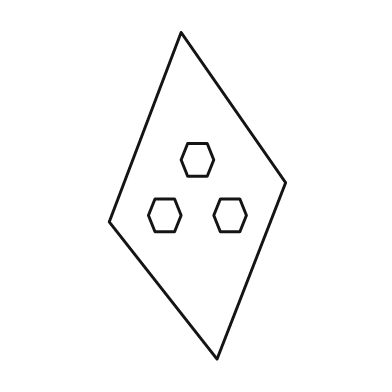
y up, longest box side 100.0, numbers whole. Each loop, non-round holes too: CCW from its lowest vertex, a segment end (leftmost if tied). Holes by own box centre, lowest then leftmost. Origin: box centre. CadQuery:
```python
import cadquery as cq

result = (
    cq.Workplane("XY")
    .moveTo(6.0, -50.0)
    .lineTo(27.0, 4.0)
    .lineTo(-5.0, 50.0)
    .lineTo(-27.0, -8.0)
    .close()
    .moveTo(-13.0, -11.0)
    .lineTo(-7.0, -11.0)
    .lineTo(-5.0, -6.0)
    .lineTo(-7.0, -1.0)
    .lineTo(-13.0, -1.0)
    .lineTo(-15.0, -6.0)
    .close()
    .moveTo(7.0, -11.0)
    .lineTo(13.0, -11.0)
    .lineTo(15.0, -6.0)
    .lineTo(13.0, -1.0)
    .lineTo(7.0, -1.0)
    .lineTo(5.0, -6.0)
    .close()
    .moveTo(-3.0, 6.0)
    .lineTo(3.0, 6.0)
    .lineTo(5.0, 11.0)
    .lineTo(3.0, 16.0)
    .lineTo(-3.0, 16.0)
    .lineTo(-5.0, 11.0)
    .close()
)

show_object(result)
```